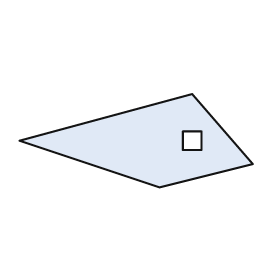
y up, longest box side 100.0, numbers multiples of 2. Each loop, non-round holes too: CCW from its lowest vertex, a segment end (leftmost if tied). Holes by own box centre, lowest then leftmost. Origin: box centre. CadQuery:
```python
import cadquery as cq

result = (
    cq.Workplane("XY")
    .moveTo(10.0, -20.0)
    .lineTo(50.0, -10.0)
    .lineTo(24.0, 20.0)
    .lineTo(-50.0, 0.0)
    .close()
    .moveTo(20.0, -4.0)
    .lineTo(28.0, -4.0)
    .lineTo(28.0, 4.0)
    .lineTo(20.0, 4.0)
    .close()
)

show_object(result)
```